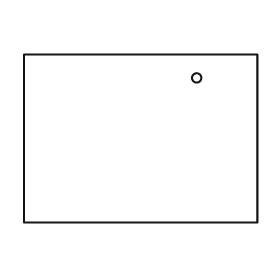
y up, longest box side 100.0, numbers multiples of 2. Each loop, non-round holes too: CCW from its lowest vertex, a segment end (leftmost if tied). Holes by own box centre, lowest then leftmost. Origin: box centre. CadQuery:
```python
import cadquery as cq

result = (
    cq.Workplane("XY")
    .moveTo(-50.0, -36.0)
    .lineTo(50.0, -36.0)
    .lineTo(50.0, 36.0)
    .lineTo(-50.0, 36.0)
    .close()
    .moveTo(24.0, 26.0)
    .circle(2.0)
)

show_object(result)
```